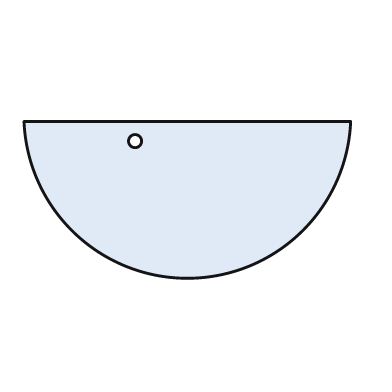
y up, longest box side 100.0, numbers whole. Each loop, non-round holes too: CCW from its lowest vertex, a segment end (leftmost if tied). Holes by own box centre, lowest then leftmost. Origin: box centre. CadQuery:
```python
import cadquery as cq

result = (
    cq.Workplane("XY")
    .moveTo(-50.0, 24.0)
    .threePointArc((0.0, -24.0), (50.0, 24.0))
    .close()
    .moveTo(-16.0, 18.0)
    .circle(2.0)
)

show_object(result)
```